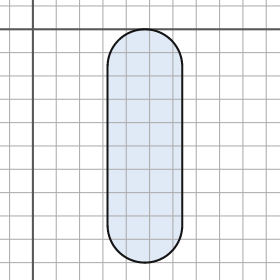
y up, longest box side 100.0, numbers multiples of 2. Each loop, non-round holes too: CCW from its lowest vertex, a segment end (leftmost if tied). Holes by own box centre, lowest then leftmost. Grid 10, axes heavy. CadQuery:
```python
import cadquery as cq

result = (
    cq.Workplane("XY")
    .moveTo(32.0, -84.0)
    .threePointArc((48.0, -100.0), (64.0, -84.0))
    .lineTo(64.0, -16.0)
    .threePointArc((48.0, 0.0), (32.0, -16.0))
    .close()
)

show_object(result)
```